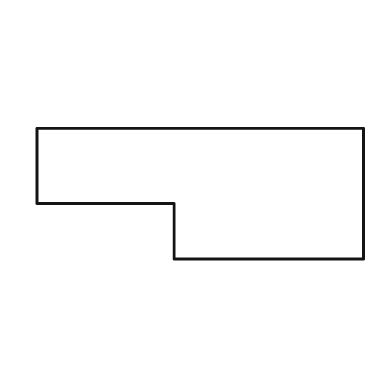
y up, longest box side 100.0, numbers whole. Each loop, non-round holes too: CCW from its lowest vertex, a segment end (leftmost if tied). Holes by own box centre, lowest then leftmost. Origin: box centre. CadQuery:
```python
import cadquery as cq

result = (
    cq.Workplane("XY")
    .moveTo(-8.0, -20.0)
    .lineTo(50.0, -20.0)
    .lineTo(50.0, 20.0)
    .lineTo(-50.0, 20.0)
    .lineTo(-50.0, -3.0)
    .lineTo(-8.0, -3.0)
    .close()
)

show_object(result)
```